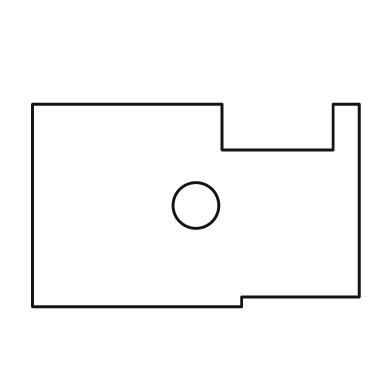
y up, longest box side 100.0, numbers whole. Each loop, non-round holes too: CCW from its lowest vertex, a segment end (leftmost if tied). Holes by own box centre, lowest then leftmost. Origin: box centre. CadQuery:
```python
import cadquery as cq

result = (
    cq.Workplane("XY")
    .moveTo(-50.0, -31.0)
    .lineTo(14.0, -31.0)
    .lineTo(14.0, -28.0)
    .lineTo(50.0, -28.0)
    .lineTo(50.0, 31.0)
    .lineTo(42.0, 31.0)
    .lineTo(42.0, 17.0)
    .lineTo(8.0, 17.0)
    .lineTo(8.0, 31.0)
    .lineTo(-50.0, 31.0)
    .close()
    .moveTo(0.0, 0.0)
    .circle(7.0)
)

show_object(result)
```